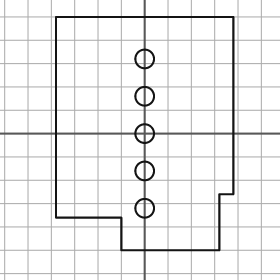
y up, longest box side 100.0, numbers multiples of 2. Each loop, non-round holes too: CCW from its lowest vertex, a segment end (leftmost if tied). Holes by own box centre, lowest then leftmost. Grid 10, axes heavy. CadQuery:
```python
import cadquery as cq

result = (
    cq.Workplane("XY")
    .moveTo(-10.0, -50.0)
    .lineTo(32.0, -50.0)
    .lineTo(32.0, -26.0)
    .lineTo(38.0, -26.0)
    .lineTo(38.0, 50.0)
    .lineTo(-38.0, 50.0)
    .lineTo(-38.0, -36.0)
    .lineTo(-10.0, -36.0)
    .close()
    .moveTo(0.0, -32.0)
    .circle(4.0)
    .moveTo(0.0, -16.0)
    .circle(4.0)
    .moveTo(0.0, 0.0)
    .circle(4.0)
    .moveTo(0.0, 16.0)
    .circle(4.0)
    .moveTo(0.0, 32.0)
    .circle(4.0)
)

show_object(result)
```